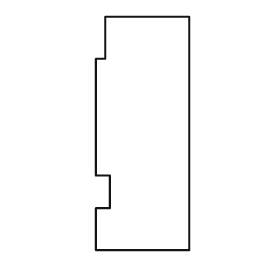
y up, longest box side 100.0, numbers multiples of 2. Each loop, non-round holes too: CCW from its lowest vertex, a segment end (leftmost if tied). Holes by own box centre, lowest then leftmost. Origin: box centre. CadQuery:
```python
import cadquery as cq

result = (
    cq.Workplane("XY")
    .moveTo(-20.0, -50.0)
    .lineTo(20.0, -50.0)
    .lineTo(20.0, 50.0)
    .lineTo(-16.0, 50.0)
    .lineTo(-16.0, 32.0)
    .lineTo(-20.0, 32.0)
    .lineTo(-20.0, -18.0)
    .lineTo(-14.0, -18.0)
    .lineTo(-14.0, -32.0)
    .lineTo(-20.0, -32.0)
    .close()
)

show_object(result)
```